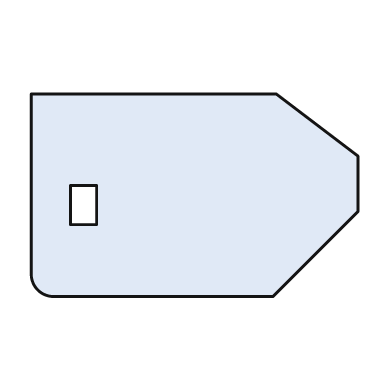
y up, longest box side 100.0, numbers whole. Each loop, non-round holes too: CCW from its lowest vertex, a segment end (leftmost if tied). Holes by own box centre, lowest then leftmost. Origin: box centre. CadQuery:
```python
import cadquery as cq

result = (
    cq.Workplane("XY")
    .moveTo(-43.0, -31.0)
    .lineTo(24.0, -31.0)
    .lineTo(50.0, -5.0)
    .lineTo(50.0, 12.0)
    .lineTo(25.0, 31.0)
    .lineTo(-50.0, 31.0)
    .lineTo(-50.0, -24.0)
    .threePointArc((-48.0, -29.0), (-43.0, -31.0))
    .close()
    .moveTo(-38.0, -9.0)
    .lineTo(-30.0, -9.0)
    .lineTo(-30.0, 3.0)
    .lineTo(-38.0, 3.0)
    .close()
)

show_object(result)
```